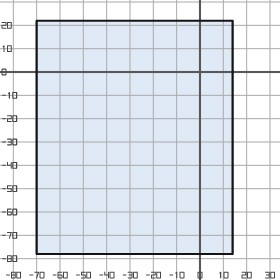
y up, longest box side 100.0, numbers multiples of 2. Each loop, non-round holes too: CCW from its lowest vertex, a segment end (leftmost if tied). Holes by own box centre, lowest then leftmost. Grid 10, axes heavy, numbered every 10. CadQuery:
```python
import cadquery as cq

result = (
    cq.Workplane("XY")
    .moveTo(-70.0, -78.0)
    .lineTo(14.0, -78.0)
    .lineTo(14.0, 22.0)
    .lineTo(-70.0, 22.0)
    .close()
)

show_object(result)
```